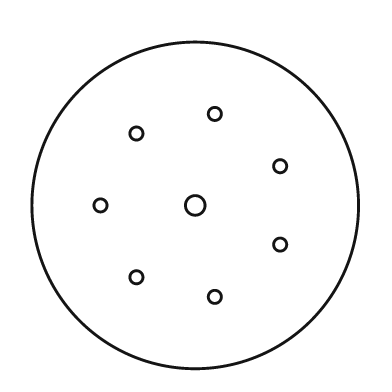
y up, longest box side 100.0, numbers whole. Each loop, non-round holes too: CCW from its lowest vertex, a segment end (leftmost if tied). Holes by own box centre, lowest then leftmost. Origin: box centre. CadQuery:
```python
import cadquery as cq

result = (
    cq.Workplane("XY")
    .moveTo(0.0, 0.0)
    .circle(50.0)
    .moveTo(6.0, -28.0)
    .circle(2.0)
    .moveTo(-18.0, -22.0)
    .circle(2.0)
    .moveTo(26.0, -12.0)
    .circle(2.0)
    .moveTo(-29.0, 0.0)
    .circle(2.0)
    .moveTo(0.0, 0.0)
    .circle(3.0)
    .moveTo(26.0, 12.0)
    .circle(2.0)
    .moveTo(-18.0, 22.0)
    .circle(2.0)
    .moveTo(6.0, 28.0)
    .circle(2.0)
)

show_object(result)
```